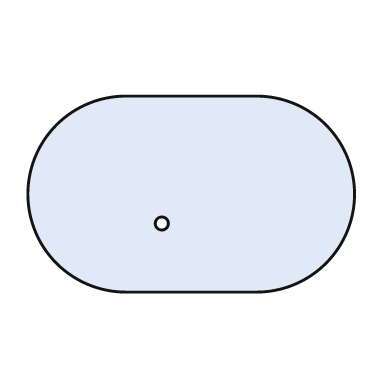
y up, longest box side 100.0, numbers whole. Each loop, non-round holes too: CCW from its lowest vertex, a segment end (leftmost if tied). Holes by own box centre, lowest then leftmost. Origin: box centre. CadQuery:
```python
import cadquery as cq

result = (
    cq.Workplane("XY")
    .moveTo(-20.0, -30.0)
    .lineTo(20.0, -30.0)
    .threePointArc((50.0, 0.0), (20.0, 30.0))
    .lineTo(-20.0, 30.0)
    .threePointArc((-50.0, 0.0), (-20.0, -30.0))
    .close()
    .moveTo(-9.0, -9.0)
    .circle(2.0)
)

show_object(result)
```